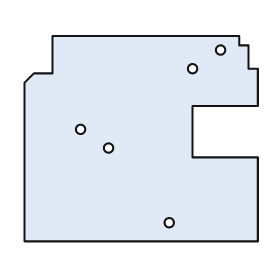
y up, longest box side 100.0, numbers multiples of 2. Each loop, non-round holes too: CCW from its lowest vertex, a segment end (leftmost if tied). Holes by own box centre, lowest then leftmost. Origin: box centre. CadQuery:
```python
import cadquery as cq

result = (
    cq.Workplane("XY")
    .moveTo(-50.0, -44.0)
    .lineTo(50.0, -44.0)
    .lineTo(50.0, -8.0)
    .lineTo(22.0, -8.0)
    .lineTo(22.0, 14.0)
    .lineTo(50.0, 14.0)
    .lineTo(50.0, 30.0)
    .lineTo(46.0, 30.0)
    .lineTo(46.0, 40.0)
    .lineTo(42.0, 40.0)
    .lineTo(42.0, 44.0)
    .lineTo(-38.0, 44.0)
    .lineTo(-38.0, 28.0)
    .lineTo(-46.0, 28.0)
    .lineTo(-50.0, 24.0)
    .close()
    .moveTo(12.0, -36.0)
    .circle(2.0)
    .moveTo(-14.0, -4.0)
    .circle(2.0)
    .moveTo(-26.0, 4.0)
    .circle(2.0)
    .moveTo(22.0, 30.0)
    .circle(2.0)
    .moveTo(34.0, 38.0)
    .circle(2.0)
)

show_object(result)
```